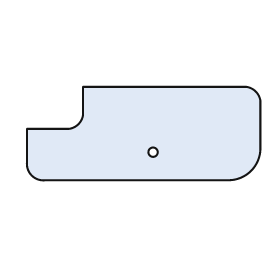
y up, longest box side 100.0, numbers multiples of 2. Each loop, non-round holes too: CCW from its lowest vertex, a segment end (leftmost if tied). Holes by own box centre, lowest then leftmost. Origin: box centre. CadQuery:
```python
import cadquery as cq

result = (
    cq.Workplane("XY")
    .moveTo(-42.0, -20.0)
    .lineTo(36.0, -20.0)
    .threePointArc((46.0, -16.0), (50.0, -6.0))
    .lineTo(50.0, 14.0)
    .threePointArc((48.0, 18.0), (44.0, 20.0))
    .lineTo(-26.0, 20.0)
    .lineTo(-26.0, 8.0)
    .threePointArc((-28.0, 4.0), (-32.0, 2.0))
    .lineTo(-50.0, 2.0)
    .lineTo(-50.0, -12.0)
    .threePointArc((-48.0, -18.0), (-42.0, -20.0))
    .close()
    .moveTo(4.0, -8.0)
    .circle(2.0)
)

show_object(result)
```